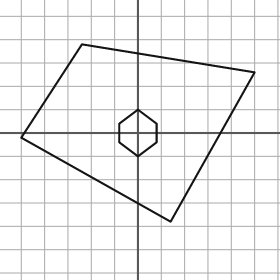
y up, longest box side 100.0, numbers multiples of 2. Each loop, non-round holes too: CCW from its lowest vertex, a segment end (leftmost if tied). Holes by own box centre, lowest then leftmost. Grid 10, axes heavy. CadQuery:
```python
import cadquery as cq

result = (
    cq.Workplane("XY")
    .moveTo(14.0, -38.0)
    .lineTo(50.0, 26.0)
    .lineTo(-24.0, 38.0)
    .lineTo(-50.0, -2.0)
    .close()
    .moveTo(0.0, -10.0)
    .lineTo(8.0, -4.0)
    .lineTo(8.0, 4.0)
    .lineTo(0.0, 10.0)
    .lineTo(-8.0, 4.0)
    .lineTo(-8.0, -4.0)
    .close()
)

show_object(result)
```